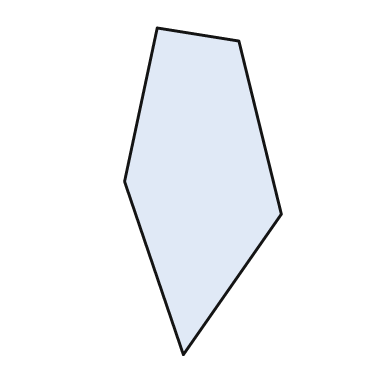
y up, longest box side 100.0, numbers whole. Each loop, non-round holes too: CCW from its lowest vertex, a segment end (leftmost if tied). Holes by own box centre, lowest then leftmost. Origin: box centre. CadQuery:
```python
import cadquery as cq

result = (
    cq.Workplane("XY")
    .moveTo(-6.0, -50.0)
    .lineTo(24.0, -7.0)
    .lineTo(11.0, 46.0)
    .lineTo(-14.0, 50.0)
    .lineTo(-24.0, 3.0)
    .close()
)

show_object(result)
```